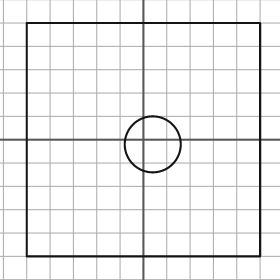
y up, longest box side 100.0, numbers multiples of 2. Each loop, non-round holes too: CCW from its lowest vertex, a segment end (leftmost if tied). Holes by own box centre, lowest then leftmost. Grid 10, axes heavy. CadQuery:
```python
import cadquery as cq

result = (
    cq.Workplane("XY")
    .moveTo(-50.0, -50.0)
    .lineTo(50.0, -50.0)
    .lineTo(50.0, 50.0)
    .lineTo(-50.0, 50.0)
    .close()
    .moveTo(4.0, -2.0)
    .circle(12.0)
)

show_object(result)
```